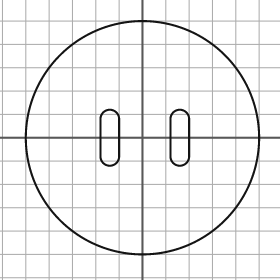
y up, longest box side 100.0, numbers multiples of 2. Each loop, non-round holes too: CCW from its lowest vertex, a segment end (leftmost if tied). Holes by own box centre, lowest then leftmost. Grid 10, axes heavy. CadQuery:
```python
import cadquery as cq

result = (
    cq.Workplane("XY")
    .moveTo(0.0, 0.0)
    .circle(50.0)
    .moveTo(-18.0, -8.0)
    .threePointArc((-14.0, -12.0), (-10.0, -8.0))
    .lineTo(-10.0, 8.0)
    .threePointArc((-14.0, 12.0), (-18.0, 8.0))
    .close()
    .moveTo(12.0, -8.0)
    .threePointArc((16.0, -12.0), (20.0, -8.0))
    .lineTo(20.0, 8.0)
    .threePointArc((16.0, 12.0), (12.0, 8.0))
    .close()
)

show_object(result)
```